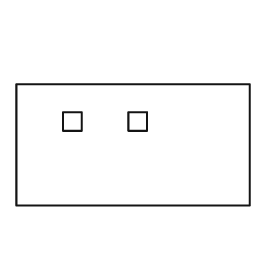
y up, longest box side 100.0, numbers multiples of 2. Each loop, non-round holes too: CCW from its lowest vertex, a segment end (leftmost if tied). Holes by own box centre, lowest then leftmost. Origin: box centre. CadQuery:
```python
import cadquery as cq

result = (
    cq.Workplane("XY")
    .moveTo(-50.0, -26.0)
    .lineTo(50.0, -26.0)
    .lineTo(50.0, 26.0)
    .lineTo(-50.0, 26.0)
    .close()
    .moveTo(-30.0, 6.0)
    .lineTo(-22.0, 6.0)
    .lineTo(-22.0, 14.0)
    .lineTo(-30.0, 14.0)
    .close()
    .moveTo(-2.0, 6.0)
    .lineTo(6.0, 6.0)
    .lineTo(6.0, 14.0)
    .lineTo(-2.0, 14.0)
    .close()
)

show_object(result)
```